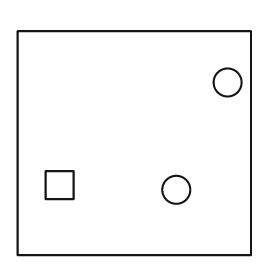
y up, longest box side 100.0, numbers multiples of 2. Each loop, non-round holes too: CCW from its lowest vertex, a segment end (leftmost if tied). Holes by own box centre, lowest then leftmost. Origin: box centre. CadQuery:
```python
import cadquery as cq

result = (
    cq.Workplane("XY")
    .moveTo(-50.0, -48.0)
    .lineTo(50.0, -48.0)
    .lineTo(50.0, 48.0)
    .lineTo(-50.0, 48.0)
    .close()
    .moveTo(18.0, -20.0)
    .circle(6.0)
    .moveTo(-38.0, -24.0)
    .lineTo(-26.0, -24.0)
    .lineTo(-26.0, -12.0)
    .lineTo(-38.0, -12.0)
    .close()
    .moveTo(40.0, 26.0)
    .circle(6.0)
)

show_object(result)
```